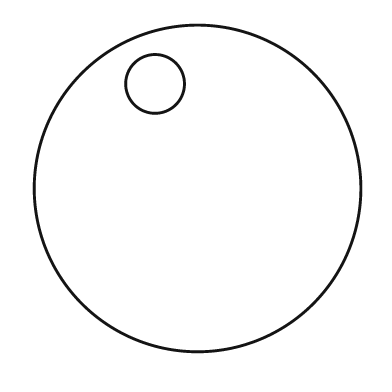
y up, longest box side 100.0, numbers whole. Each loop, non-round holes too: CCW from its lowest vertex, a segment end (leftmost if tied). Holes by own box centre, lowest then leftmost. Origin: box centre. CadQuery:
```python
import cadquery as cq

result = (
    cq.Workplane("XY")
    .moveTo(0.0, 0.0)
    .circle(50.0)
    .moveTo(-13.0, 32.0)
    .circle(9.0)
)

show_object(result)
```